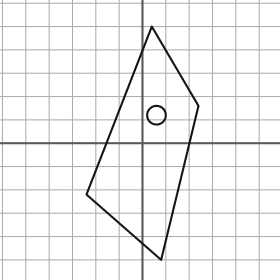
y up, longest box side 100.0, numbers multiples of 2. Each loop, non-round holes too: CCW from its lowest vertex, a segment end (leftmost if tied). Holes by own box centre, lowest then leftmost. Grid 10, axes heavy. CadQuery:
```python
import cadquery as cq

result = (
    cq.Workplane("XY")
    .moveTo(8.0, -50.0)
    .lineTo(24.0, 16.0)
    .lineTo(4.0, 50.0)
    .lineTo(-24.0, -22.0)
    .close()
    .moveTo(6.0, 12.0)
    .circle(4.0)
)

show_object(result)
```